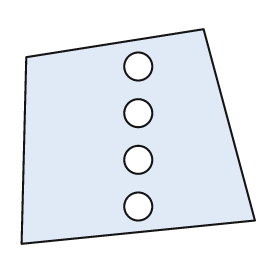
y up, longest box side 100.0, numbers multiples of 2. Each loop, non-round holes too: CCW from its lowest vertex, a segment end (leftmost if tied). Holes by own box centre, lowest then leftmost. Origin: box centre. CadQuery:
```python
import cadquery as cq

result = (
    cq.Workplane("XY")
    .moveTo(-50.0, -46.0)
    .lineTo(50.0, -36.0)
    .lineTo(28.0, 46.0)
    .lineTo(-48.0, 34.0)
    .close()
    .moveTo(0.0, -30.0)
    .circle(6.0)
    .moveTo(0.0, -10.0)
    .circle(6.0)
    .moveTo(0.0, 10.0)
    .circle(6.0)
    .moveTo(0.0, 30.0)
    .circle(6.0)
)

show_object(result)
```